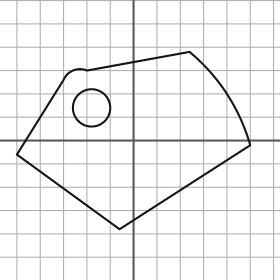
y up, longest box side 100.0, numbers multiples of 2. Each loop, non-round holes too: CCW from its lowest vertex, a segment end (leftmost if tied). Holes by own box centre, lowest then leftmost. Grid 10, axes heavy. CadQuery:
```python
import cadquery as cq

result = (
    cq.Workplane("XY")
    .moveTo(-6.0, -38.0)
    .lineTo(50.0, -2.0)
    .threePointArc((40.0, 20.0), (24.0, 38.0))
    .lineTo(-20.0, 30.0)
    .threePointArc((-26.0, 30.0), (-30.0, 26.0))
    .lineTo(-50.0, -6.0)
    .close()
    .moveTo(-18.0, 14.0)
    .circle(8.0)
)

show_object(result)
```